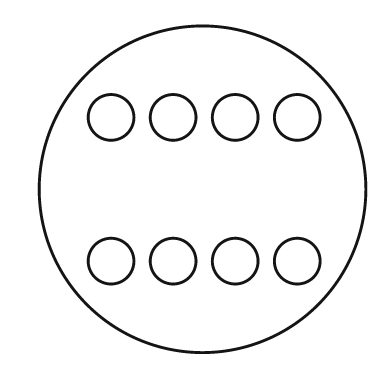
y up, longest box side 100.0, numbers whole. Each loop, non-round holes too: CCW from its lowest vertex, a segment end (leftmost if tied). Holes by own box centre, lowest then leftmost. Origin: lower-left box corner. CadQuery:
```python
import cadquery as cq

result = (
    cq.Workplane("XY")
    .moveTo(50.0, 50.0)
    .circle(50.0)
    .moveTo(22.0, 28.0)
    .circle(7.0)
    .moveTo(41.0, 28.0)
    .circle(7.0)
    .moveTo(60.0, 28.0)
    .circle(7.0)
    .moveTo(79.0, 28.0)
    .circle(7.0)
    .moveTo(22.0, 72.0)
    .circle(7.0)
    .moveTo(41.0, 72.0)
    .circle(7.0)
    .moveTo(60.0, 72.0)
    .circle(7.0)
    .moveTo(79.0, 72.0)
    .circle(7.0)
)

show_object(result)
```